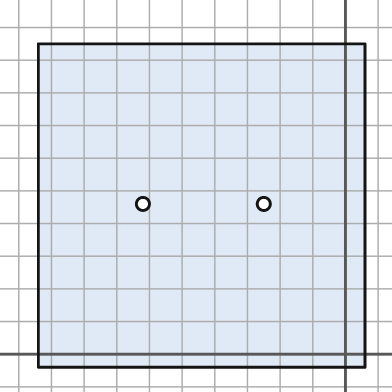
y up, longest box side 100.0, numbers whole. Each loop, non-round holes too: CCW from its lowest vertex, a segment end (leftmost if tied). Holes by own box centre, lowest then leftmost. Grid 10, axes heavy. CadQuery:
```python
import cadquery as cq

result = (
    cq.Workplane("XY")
    .moveTo(-94.0, -4.0)
    .lineTo(6.0, -4.0)
    .lineTo(6.0, 95.0)
    .lineTo(-94.0, 95.0)
    .close()
    .moveTo(-62.0, 46.0)
    .circle(2.0)
    .moveTo(-25.0, 46.0)
    .circle(2.0)
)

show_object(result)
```